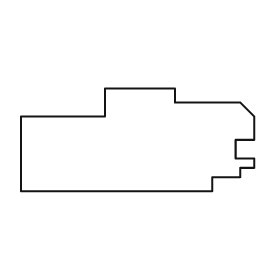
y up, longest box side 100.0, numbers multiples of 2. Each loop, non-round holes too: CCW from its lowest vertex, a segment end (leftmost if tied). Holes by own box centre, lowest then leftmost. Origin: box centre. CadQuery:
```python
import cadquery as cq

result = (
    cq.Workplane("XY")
    .moveTo(-50.0, -22.0)
    .lineTo(32.0, -22.0)
    .lineTo(32.0, -16.0)
    .lineTo(44.0, -16.0)
    .lineTo(44.0, -12.0)
    .lineTo(50.0, -12.0)
    .lineTo(50.0, -8.0)
    .lineTo(42.0, -8.0)
    .lineTo(42.0, 0.0)
    .lineTo(50.0, 0.0)
    .lineTo(50.0, 10.0)
    .lineTo(44.0, 16.0)
    .lineTo(16.0, 16.0)
    .lineTo(16.0, 22.0)
    .lineTo(-14.0, 22.0)
    .lineTo(-14.0, 10.0)
    .lineTo(-50.0, 10.0)
    .close()
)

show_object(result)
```